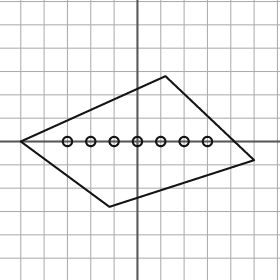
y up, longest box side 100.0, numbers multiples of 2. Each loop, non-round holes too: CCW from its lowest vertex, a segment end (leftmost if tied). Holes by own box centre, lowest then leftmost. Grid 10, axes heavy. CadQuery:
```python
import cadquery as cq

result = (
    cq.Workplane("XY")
    .moveTo(-12.0, -28.0)
    .lineTo(50.0, -8.0)
    .lineTo(12.0, 28.0)
    .lineTo(-50.0, 0.0)
    .close()
    .moveTo(-30.0, 0.0)
    .circle(2.0)
    .moveTo(-20.0, 0.0)
    .circle(2.0)
    .moveTo(-10.0, 0.0)
    .circle(2.0)
    .moveTo(0.0, 0.0)
    .circle(2.0)
    .moveTo(10.0, 0.0)
    .circle(2.0)
    .moveTo(20.0, 0.0)
    .circle(2.0)
    .moveTo(30.0, 0.0)
    .circle(2.0)
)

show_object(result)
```